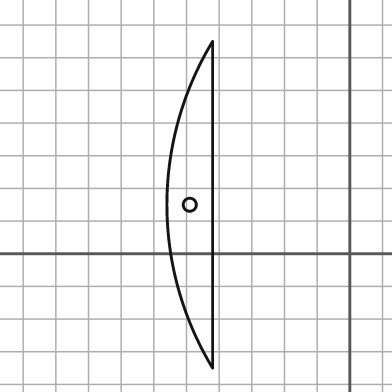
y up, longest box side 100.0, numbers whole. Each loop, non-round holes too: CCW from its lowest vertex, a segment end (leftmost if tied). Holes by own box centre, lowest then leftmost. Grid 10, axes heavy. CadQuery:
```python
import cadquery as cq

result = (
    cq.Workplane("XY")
    .moveTo(-42.0, -35.0)
    .lineTo(-42.0, 65.0)
    .threePointArc((-56.0, 15.0), (-42.0, -35.0))
    .close()
    .moveTo(-49.0, 15.0)
    .circle(2.0)
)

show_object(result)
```